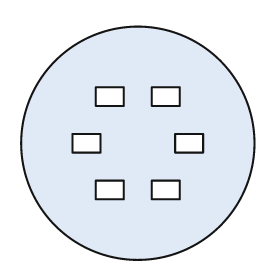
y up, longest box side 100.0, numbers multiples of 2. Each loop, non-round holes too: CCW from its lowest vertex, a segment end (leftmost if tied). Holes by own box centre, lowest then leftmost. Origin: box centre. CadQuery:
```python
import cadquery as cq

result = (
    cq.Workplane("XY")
    .moveTo(0.0, 0.0)
    .circle(50.0)
    .moveTo(-18.0, -24.0)
    .lineTo(-6.0, -24.0)
    .lineTo(-6.0, -16.0)
    .lineTo(-18.0, -16.0)
    .close()
    .moveTo(6.0, -24.0)
    .lineTo(18.0, -24.0)
    .lineTo(18.0, -16.0)
    .lineTo(6.0, -16.0)
    .close()
    .moveTo(-28.0, -4.0)
    .lineTo(-16.0, -4.0)
    .lineTo(-16.0, 4.0)
    .lineTo(-28.0, 4.0)
    .close()
    .moveTo(16.0, -4.0)
    .lineTo(28.0, -4.0)
    .lineTo(28.0, 4.0)
    .lineTo(16.0, 4.0)
    .close()
    .moveTo(-18.0, 16.0)
    .lineTo(-6.0, 16.0)
    .lineTo(-6.0, 24.0)
    .lineTo(-18.0, 24.0)
    .close()
    .moveTo(6.0, 16.0)
    .lineTo(18.0, 16.0)
    .lineTo(18.0, 24.0)
    .lineTo(6.0, 24.0)
    .close()
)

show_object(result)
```